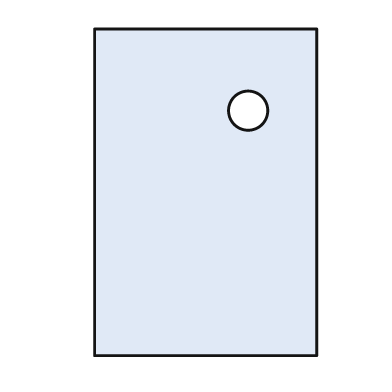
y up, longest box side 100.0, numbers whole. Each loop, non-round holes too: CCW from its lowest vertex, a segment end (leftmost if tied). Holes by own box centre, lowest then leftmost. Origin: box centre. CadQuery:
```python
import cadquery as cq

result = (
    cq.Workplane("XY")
    .moveTo(-34.0, -50.0)
    .lineTo(34.0, -50.0)
    .lineTo(34.0, 50.0)
    .lineTo(-34.0, 50.0)
    .close()
    .moveTo(13.0, 25.0)
    .circle(6.0)
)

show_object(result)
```